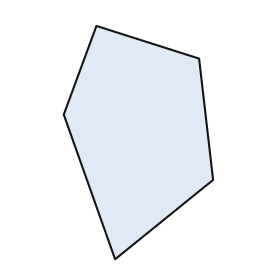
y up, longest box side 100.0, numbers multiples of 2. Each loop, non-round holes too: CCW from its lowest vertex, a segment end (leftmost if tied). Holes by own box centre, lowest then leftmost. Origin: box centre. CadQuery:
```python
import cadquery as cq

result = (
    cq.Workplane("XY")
    .moveTo(-10.0, -50.0)
    .lineTo(32.0, -16.0)
    .lineTo(26.0, 36.0)
    .lineTo(-18.0, 50.0)
    .lineTo(-32.0, 12.0)
    .close()
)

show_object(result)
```